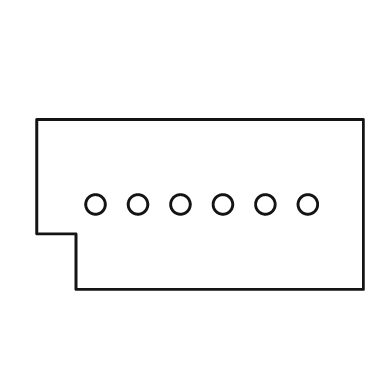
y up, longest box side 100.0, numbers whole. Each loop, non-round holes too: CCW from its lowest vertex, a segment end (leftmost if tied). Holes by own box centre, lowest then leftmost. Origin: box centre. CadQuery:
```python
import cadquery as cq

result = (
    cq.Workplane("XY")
    .moveTo(-38.0, -26.0)
    .lineTo(50.0, -26.0)
    .lineTo(50.0, 26.0)
    .lineTo(-50.0, 26.0)
    .lineTo(-50.0, -9.0)
    .lineTo(-38.0, -9.0)
    .close()
    .moveTo(-32.0, 0.0)
    .circle(3.0)
    .moveTo(-19.0, 0.0)
    .circle(3.0)
    .moveTo(-6.0, 0.0)
    .circle(3.0)
    .moveTo(7.0, 0.0)
    .circle(3.0)
    .moveTo(20.0, 0.0)
    .circle(3.0)
    .moveTo(33.0, 0.0)
    .circle(3.0)
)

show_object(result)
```